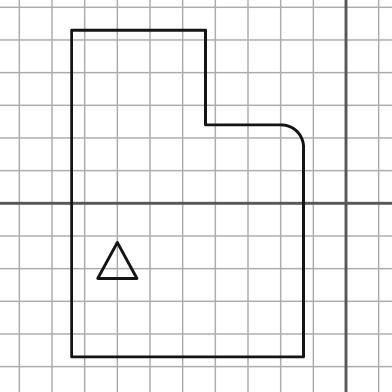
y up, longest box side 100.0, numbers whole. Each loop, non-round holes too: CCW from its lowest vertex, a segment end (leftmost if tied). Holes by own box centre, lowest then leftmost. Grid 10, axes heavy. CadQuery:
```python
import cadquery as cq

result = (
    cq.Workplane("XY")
    .moveTo(-84.0, -47.0)
    .lineTo(-13.0, -47.0)
    .lineTo(-13.0, 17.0)
    .threePointArc((-15.0, 22.0), (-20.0, 24.0))
    .lineTo(-43.0, 24.0)
    .lineTo(-43.0, 53.0)
    .lineTo(-84.0, 53.0)
    .close()
    .moveTo(-76.0, -23.0)
    .lineTo(-64.0, -23.0)
    .lineTo(-70.0, -12.0)
    .close()
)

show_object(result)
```